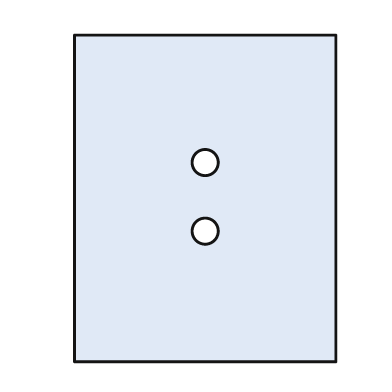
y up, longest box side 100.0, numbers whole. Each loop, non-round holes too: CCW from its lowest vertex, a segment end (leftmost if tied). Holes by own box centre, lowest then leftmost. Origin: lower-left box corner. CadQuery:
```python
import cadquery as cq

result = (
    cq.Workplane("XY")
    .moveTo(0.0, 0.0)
    .lineTo(80.0, 0.0)
    .lineTo(80.0, 100.0)
    .lineTo(0.0, 100.0)
    .close()
    .moveTo(40.0, 40.0)
    .circle(4.0)
    .moveTo(40.0, 61.0)
    .circle(4.0)
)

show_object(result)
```